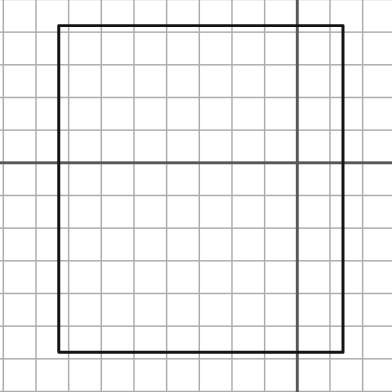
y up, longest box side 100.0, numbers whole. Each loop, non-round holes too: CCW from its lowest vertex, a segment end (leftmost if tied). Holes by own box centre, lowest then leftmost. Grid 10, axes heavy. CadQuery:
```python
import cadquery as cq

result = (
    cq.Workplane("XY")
    .moveTo(-73.0, -58.0)
    .lineTo(14.0, -58.0)
    .lineTo(14.0, 42.0)
    .lineTo(-73.0, 42.0)
    .close()
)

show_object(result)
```